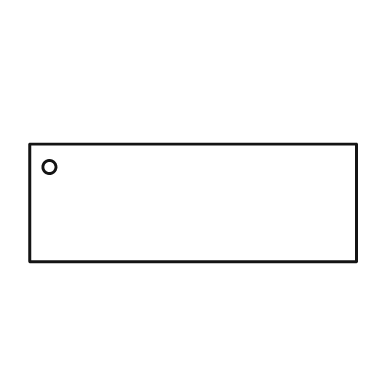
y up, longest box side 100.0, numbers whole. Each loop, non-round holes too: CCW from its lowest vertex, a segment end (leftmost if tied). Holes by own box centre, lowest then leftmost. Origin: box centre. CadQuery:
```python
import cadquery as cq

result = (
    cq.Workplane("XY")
    .moveTo(-50.0, -18.0)
    .lineTo(50.0, -18.0)
    .lineTo(50.0, 18.0)
    .lineTo(-50.0, 18.0)
    .close()
    .moveTo(-44.0, 11.0)
    .circle(2.0)
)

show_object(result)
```